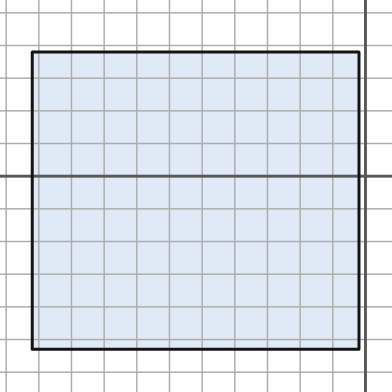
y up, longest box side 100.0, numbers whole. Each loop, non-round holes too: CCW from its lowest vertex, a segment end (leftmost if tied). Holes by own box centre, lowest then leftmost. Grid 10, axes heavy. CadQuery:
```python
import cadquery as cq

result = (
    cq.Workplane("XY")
    .moveTo(-102.0, -53.0)
    .lineTo(-2.0, -53.0)
    .lineTo(-2.0, 38.0)
    .lineTo(-102.0, 38.0)
    .close()
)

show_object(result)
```